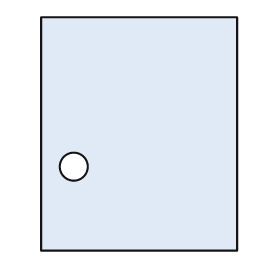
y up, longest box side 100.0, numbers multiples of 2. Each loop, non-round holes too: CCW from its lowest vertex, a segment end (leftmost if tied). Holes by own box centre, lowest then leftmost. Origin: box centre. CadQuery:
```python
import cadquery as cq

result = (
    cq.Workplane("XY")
    .moveTo(-42.0, -50.0)
    .lineTo(42.0, -50.0)
    .lineTo(42.0, 50.0)
    .lineTo(-42.0, 50.0)
    .close()
    .moveTo(-28.0, -14.0)
    .circle(6.0)
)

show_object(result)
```